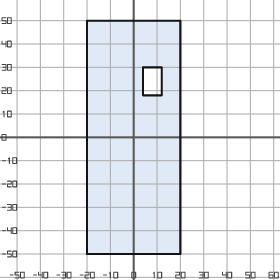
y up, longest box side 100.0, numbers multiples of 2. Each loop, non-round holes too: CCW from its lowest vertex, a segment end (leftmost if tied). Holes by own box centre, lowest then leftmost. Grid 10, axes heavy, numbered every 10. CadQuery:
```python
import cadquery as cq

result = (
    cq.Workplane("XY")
    .moveTo(-20.0, -50.0)
    .lineTo(20.0, -50.0)
    .lineTo(20.0, 50.0)
    .lineTo(-20.0, 50.0)
    .close()
    .moveTo(4.0, 18.0)
    .lineTo(12.0, 18.0)
    .lineTo(12.0, 30.0)
    .lineTo(4.0, 30.0)
    .close()
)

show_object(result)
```